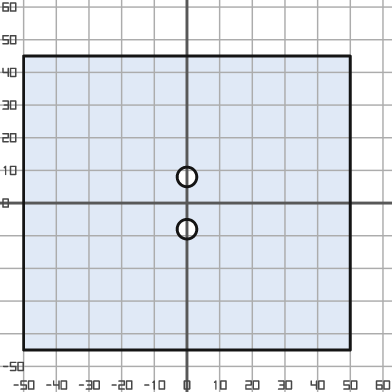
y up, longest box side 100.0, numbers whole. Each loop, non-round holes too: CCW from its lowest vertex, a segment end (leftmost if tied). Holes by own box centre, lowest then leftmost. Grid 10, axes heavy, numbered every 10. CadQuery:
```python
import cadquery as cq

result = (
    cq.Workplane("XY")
    .moveTo(-50.0, -45.0)
    .lineTo(50.0, -45.0)
    .lineTo(50.0, 45.0)
    .lineTo(-50.0, 45.0)
    .close()
    .moveTo(0.0, -8.0)
    .circle(3.0)
    .moveTo(0.0, 8.0)
    .circle(3.0)
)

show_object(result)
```